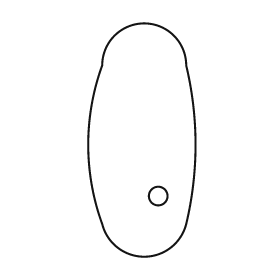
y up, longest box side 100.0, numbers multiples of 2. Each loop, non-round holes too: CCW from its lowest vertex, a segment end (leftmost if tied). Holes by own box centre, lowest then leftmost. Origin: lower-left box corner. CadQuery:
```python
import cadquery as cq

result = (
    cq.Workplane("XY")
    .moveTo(6.0, 14.0)
    .threePointArc((24.0, 0.0), (42.0, 14.0))
    .threePointArc((46.0, 48.0), (42.0, 82.0))
    .threePointArc((24.0, 100.0), (6.0, 82.0))
    .threePointArc((0.0, 48.0), (6.0, 14.0))
    .close()
    .moveTo(30.0, 26.0)
    .circle(4.0)
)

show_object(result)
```